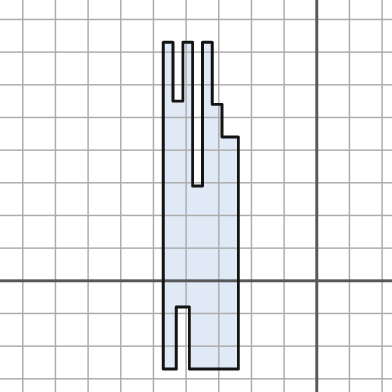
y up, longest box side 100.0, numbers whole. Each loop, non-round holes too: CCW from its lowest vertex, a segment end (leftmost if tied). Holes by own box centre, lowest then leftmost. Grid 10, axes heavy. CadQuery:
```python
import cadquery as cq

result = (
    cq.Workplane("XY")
    .moveTo(-47.0, -27.0)
    .lineTo(-43.0, -27.0)
    .lineTo(-43.0, -8.0)
    .lineTo(-39.0, -8.0)
    .lineTo(-39.0, -27.0)
    .lineTo(-24.0, -27.0)
    .lineTo(-24.0, 44.0)
    .lineTo(-29.0, 44.0)
    .lineTo(-29.0, 54.0)
    .lineTo(-32.0, 54.0)
    .lineTo(-32.0, 73.0)
    .lineTo(-35.0, 73.0)
    .lineTo(-35.0, 29.0)
    .lineTo(-38.0, 29.0)
    .lineTo(-38.0, 73.0)
    .lineTo(-41.0, 73.0)
    .lineTo(-41.0, 55.0)
    .lineTo(-44.0, 55.0)
    .lineTo(-44.0, 73.0)
    .lineTo(-47.0, 73.0)
    .close()
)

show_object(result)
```